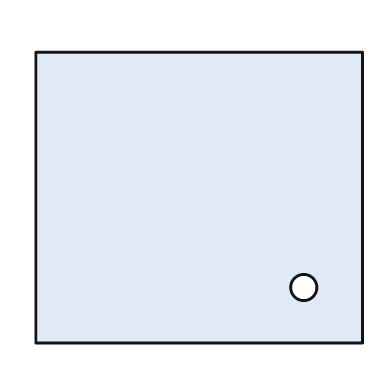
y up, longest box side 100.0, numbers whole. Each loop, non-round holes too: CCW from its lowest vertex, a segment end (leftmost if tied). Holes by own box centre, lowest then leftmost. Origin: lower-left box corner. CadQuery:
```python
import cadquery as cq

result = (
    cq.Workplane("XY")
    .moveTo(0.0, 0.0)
    .lineTo(100.0, 0.0)
    .lineTo(100.0, 89.0)
    .lineTo(0.0, 89.0)
    .close()
    .moveTo(82.0, 17.0)
    .circle(4.0)
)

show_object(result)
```